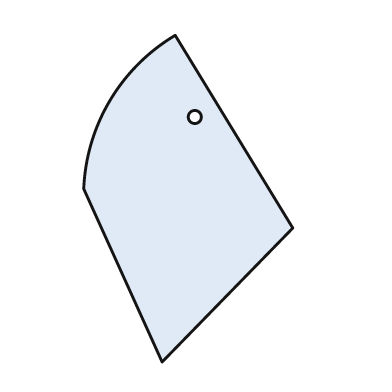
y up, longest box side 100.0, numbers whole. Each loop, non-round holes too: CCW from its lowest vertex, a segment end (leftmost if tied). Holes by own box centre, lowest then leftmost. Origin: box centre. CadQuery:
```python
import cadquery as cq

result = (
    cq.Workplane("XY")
    .moveTo(-8.0, -50.0)
    .lineTo(32.0, -9.0)
    .lineTo(-4.0, 50.0)
    .threePointArc((-24.0, 30.0), (-32.0, 3.0))
    .close()
    .moveTo(2.0, 25.0)
    .circle(2.0)
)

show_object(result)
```